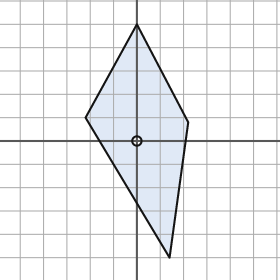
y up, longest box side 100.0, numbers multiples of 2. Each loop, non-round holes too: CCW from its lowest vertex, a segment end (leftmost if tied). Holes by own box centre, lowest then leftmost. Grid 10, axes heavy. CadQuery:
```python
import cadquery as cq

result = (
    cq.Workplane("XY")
    .moveTo(14.0, -50.0)
    .lineTo(22.0, 8.0)
    .lineTo(0.0, 50.0)
    .lineTo(-22.0, 10.0)
    .close()
    .moveTo(0.0, 0.0)
    .circle(2.0)
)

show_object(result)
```